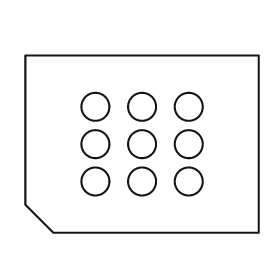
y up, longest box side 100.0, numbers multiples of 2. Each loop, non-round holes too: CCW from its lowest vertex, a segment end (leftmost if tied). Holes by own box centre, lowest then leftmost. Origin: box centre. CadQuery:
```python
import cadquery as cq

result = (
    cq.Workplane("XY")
    .moveTo(-38.0, -38.0)
    .lineTo(50.0, -38.0)
    .lineTo(50.0, 38.0)
    .lineTo(-50.0, 38.0)
    .lineTo(-50.0, -26.0)
    .close()
    .moveTo(-20.0, -16.0)
    .circle(6.0)
    .moveTo(0.0, -16.0)
    .circle(6.0)
    .moveTo(20.0, -16.0)
    .circle(6.0)
    .moveTo(-20.0, 0.0)
    .circle(6.0)
    .moveTo(0.0, 0.0)
    .circle(6.0)
    .moveTo(20.0, 0.0)
    .circle(6.0)
    .moveTo(-20.0, 16.0)
    .circle(6.0)
    .moveTo(0.0, 16.0)
    .circle(6.0)
    .moveTo(20.0, 16.0)
    .circle(6.0)
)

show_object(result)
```